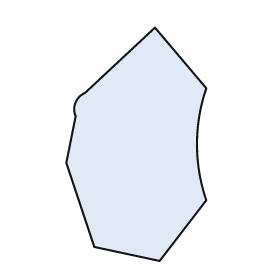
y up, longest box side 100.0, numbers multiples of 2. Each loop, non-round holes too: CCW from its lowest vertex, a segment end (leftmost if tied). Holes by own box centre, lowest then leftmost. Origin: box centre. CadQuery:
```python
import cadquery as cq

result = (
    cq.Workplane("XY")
    .moveTo(10.0, -50.0)
    .lineTo(30.0, -24.0)
    .threePointArc((26.0, 0.0), (30.0, 24.0))
    .lineTo(8.0, 50.0)
    .lineTo(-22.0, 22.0)
    .threePointArc((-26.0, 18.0), (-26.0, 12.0))
    .lineTo(-30.0, -8.0)
    .lineTo(-18.0, -44.0)
    .close()
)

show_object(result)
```